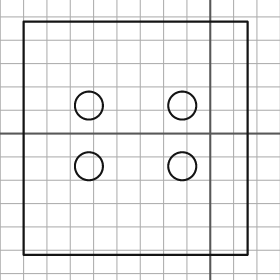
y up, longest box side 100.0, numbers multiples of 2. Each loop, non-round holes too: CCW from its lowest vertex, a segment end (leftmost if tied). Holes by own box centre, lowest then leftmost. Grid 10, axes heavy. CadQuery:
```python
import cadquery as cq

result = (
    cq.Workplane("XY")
    .moveTo(-80.0, -52.0)
    .lineTo(16.0, -52.0)
    .lineTo(16.0, 48.0)
    .lineTo(-80.0, 48.0)
    .close()
    .moveTo(-52.0, -14.0)
    .circle(6.0)
    .moveTo(-12.0, -14.0)
    .circle(6.0)
    .moveTo(-52.0, 12.0)
    .circle(6.0)
    .moveTo(-12.0, 12.0)
    .circle(6.0)
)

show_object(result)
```